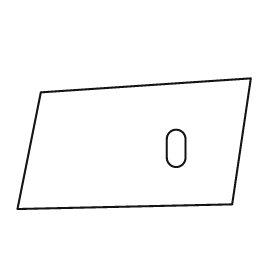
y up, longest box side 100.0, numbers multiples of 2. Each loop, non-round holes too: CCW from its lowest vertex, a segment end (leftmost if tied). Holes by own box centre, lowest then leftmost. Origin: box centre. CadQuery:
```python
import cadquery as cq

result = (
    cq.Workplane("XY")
    .moveTo(-50.0, -28.0)
    .lineTo(42.0, -26.0)
    .lineTo(50.0, 28.0)
    .lineTo(-40.0, 22.0)
    .close()
    .moveTo(14.0, -6.0)
    .threePointArc((18.0, -10.0), (22.0, -6.0))
    .lineTo(22.0, 2.0)
    .threePointArc((18.0, 6.0), (14.0, 2.0))
    .close()
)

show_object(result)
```